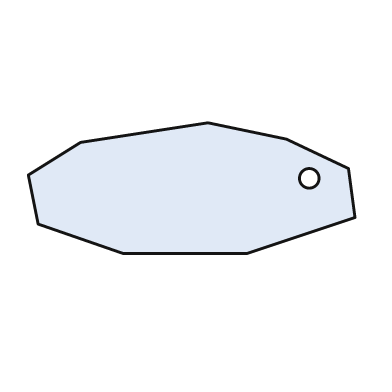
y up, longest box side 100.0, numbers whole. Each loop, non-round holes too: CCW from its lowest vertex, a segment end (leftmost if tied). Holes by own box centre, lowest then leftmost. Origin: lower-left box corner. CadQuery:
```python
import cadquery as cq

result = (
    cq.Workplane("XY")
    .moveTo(29.0, 0.0)
    .lineTo(67.0, 0.0)
    .lineTo(100.0, 11.0)
    .lineTo(98.0, 26.0)
    .lineTo(79.0, 35.0)
    .lineTo(55.0, 40.0)
    .lineTo(16.0, 34.0)
    .lineTo(0.0, 24.0)
    .lineTo(3.0, 9.0)
    .close()
    .moveTo(86.0, 23.0)
    .circle(3.0)
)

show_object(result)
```